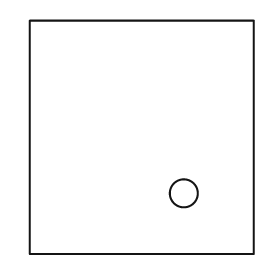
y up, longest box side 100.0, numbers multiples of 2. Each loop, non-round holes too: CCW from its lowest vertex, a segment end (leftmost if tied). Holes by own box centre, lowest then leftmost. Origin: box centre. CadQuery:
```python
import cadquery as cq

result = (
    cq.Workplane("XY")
    .moveTo(-48.0, -50.0)
    .lineTo(48.0, -50.0)
    .lineTo(48.0, 50.0)
    .lineTo(-48.0, 50.0)
    .close()
    .moveTo(18.0, -24.0)
    .circle(6.0)
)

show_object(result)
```